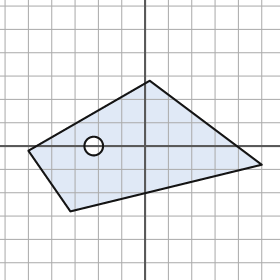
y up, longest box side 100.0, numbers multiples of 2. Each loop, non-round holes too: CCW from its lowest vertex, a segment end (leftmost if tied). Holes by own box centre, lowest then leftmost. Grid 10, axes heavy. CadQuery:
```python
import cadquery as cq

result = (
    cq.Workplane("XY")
    .moveTo(-32.0, -28.0)
    .lineTo(50.0, -8.0)
    .lineTo(2.0, 28.0)
    .lineTo(-50.0, -2.0)
    .close()
    .moveTo(-22.0, 0.0)
    .circle(4.0)
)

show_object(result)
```